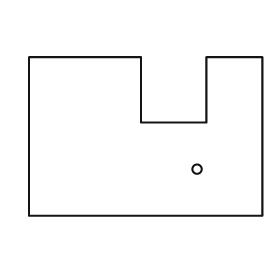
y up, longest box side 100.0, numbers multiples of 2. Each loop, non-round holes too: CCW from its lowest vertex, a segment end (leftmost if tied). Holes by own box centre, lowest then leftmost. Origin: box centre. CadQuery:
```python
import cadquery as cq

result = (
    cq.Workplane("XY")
    .moveTo(-50.0, -34.0)
    .lineTo(50.0, -34.0)
    .lineTo(50.0, 34.0)
    .lineTo(26.0, 34.0)
    .lineTo(26.0, 6.0)
    .lineTo(-2.0, 6.0)
    .lineTo(-2.0, 34.0)
    .lineTo(-50.0, 34.0)
    .close()
    .moveTo(22.0, -14.0)
    .circle(2.0)
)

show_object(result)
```